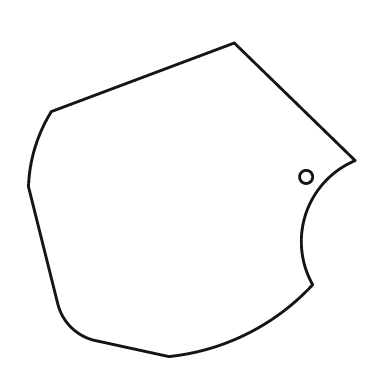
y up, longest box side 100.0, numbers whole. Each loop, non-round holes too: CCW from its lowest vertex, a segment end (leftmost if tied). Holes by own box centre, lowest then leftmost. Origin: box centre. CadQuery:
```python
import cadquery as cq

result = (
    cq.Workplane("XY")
    .moveTo(-7.0, -48.0)
    .threePointArc((17.0, -41.0), (37.0, -26.0))
    .threePointArc((35.0, -4.0), (50.0, 12.0))
    .lineTo(13.0, 48.0)
    .lineTo(-43.0, 27.0)
    .threePointArc((-48.0, 16.0), (-50.0, 4.0))
    .lineTo(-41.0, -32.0)
    .threePointArc((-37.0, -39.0), (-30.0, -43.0))
    .close()
    .moveTo(35.0, 7.0)
    .circle(2.0)
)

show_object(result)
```